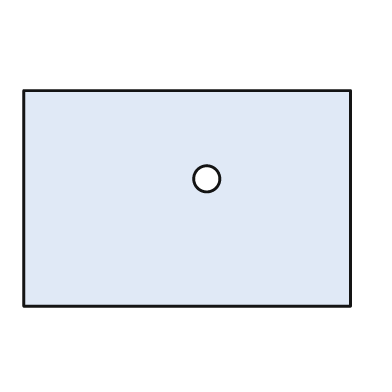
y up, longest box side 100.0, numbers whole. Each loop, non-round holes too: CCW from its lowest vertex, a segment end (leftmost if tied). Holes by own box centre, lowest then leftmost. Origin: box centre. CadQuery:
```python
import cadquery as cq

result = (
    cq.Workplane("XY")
    .moveTo(-50.0, -33.0)
    .lineTo(50.0, -33.0)
    .lineTo(50.0, 33.0)
    .lineTo(-50.0, 33.0)
    .close()
    .moveTo(6.0, 6.0)
    .circle(4.0)
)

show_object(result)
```